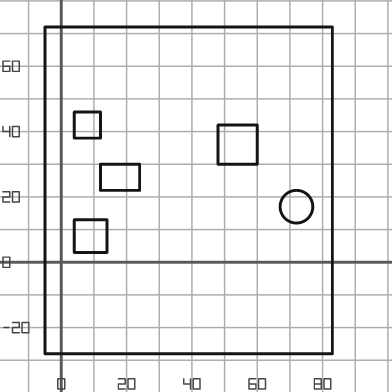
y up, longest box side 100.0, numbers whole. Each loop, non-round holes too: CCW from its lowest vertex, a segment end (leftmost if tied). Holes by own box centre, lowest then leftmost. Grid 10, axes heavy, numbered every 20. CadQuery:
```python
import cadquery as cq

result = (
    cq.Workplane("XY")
    .moveTo(-5.0, -28.0)
    .lineTo(83.0, -28.0)
    .lineTo(83.0, 72.0)
    .lineTo(-5.0, 72.0)
    .close()
    .moveTo(4.0, 3.0)
    .lineTo(14.0, 3.0)
    .lineTo(14.0, 13.0)
    .lineTo(4.0, 13.0)
    .close()
    .moveTo(72.0, 17.0)
    .circle(5.0)
    .moveTo(12.0, 22.0)
    .lineTo(24.0, 22.0)
    .lineTo(24.0, 30.0)
    .lineTo(12.0, 30.0)
    .close()
    .moveTo(48.0, 30.0)
    .lineTo(60.0, 30.0)
    .lineTo(60.0, 42.0)
    .lineTo(48.0, 42.0)
    .close()
    .moveTo(4.0, 38.0)
    .lineTo(12.0, 38.0)
    .lineTo(12.0, 46.0)
    .lineTo(4.0, 46.0)
    .close()
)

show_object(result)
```